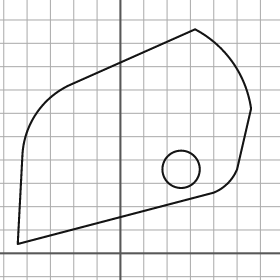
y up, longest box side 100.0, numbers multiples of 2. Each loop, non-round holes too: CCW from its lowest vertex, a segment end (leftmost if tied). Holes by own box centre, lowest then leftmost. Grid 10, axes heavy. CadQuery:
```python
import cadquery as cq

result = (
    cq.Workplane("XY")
    .moveTo(-44.0, 4.0)
    .lineTo(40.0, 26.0)
    .threePointArc((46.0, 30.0), (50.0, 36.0))
    .lineTo(56.0, 62.0)
    .threePointArc((48.0, 82.0), (32.0, 96.0))
    .lineTo(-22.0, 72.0)
    .threePointArc((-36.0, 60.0), (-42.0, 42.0))
    .close()
    .moveTo(26.0, 36.0)
    .circle(8.0)
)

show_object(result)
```